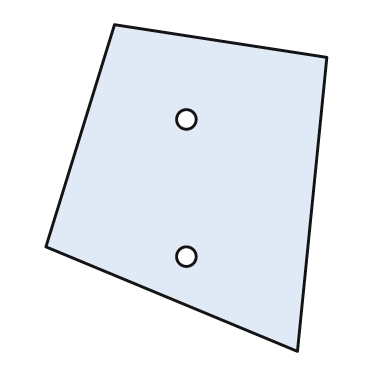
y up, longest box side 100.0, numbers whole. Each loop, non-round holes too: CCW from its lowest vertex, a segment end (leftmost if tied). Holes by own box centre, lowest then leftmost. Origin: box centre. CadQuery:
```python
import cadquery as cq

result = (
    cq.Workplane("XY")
    .moveTo(34.0, -50.0)
    .lineTo(43.0, 40.0)
    .lineTo(-22.0, 50.0)
    .lineTo(-43.0, -18.0)
    .close()
    .moveTo(0.0, -21.0)
    .circle(3.0)
    .moveTo(0.0, 21.0)
    .circle(3.0)
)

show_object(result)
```